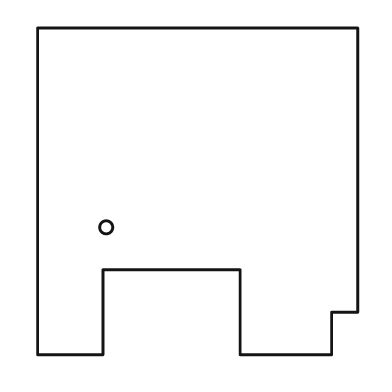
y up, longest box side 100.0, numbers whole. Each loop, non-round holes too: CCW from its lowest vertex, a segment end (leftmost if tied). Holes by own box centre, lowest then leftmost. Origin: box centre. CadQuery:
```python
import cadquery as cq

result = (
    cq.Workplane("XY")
    .moveTo(-49.0, -50.0)
    .lineTo(-29.0, -50.0)
    .lineTo(-29.0, -24.0)
    .lineTo(13.0, -24.0)
    .lineTo(13.0, -50.0)
    .lineTo(41.0, -50.0)
    .lineTo(41.0, -37.0)
    .lineTo(49.0, -37.0)
    .lineTo(49.0, 50.0)
    .lineTo(-49.0, 50.0)
    .close()
    .moveTo(-28.0, -11.0)
    .circle(2.0)
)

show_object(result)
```